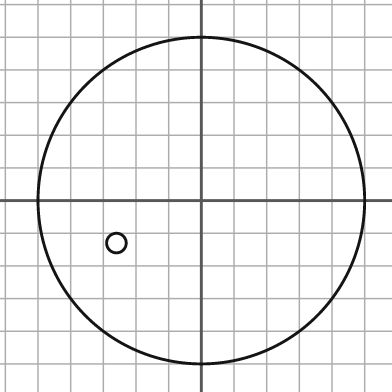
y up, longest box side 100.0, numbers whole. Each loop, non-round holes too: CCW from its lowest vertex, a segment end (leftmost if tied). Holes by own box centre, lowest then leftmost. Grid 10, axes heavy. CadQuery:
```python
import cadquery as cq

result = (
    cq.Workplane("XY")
    .moveTo(0.0, 0.0)
    .circle(50.0)
    .moveTo(-26.0, -13.0)
    .circle(3.0)
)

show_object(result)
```